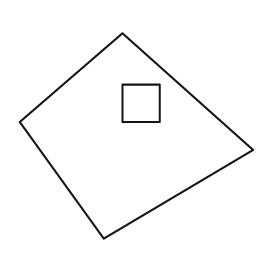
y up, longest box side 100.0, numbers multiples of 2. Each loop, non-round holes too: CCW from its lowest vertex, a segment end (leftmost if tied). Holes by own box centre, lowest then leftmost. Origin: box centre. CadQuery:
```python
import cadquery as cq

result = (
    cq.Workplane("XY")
    .moveTo(-14.0, -44.0)
    .lineTo(50.0, -6.0)
    .lineTo(-6.0, 44.0)
    .lineTo(-50.0, 6.0)
    .close()
    .moveTo(-6.0, 6.0)
    .lineTo(10.0, 6.0)
    .lineTo(10.0, 22.0)
    .lineTo(-6.0, 22.0)
    .close()
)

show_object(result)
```